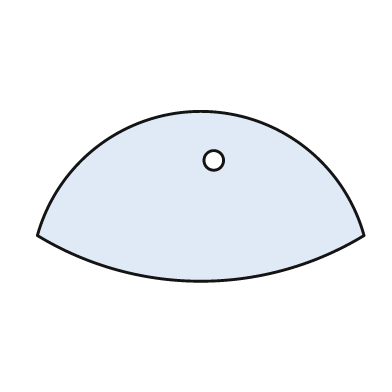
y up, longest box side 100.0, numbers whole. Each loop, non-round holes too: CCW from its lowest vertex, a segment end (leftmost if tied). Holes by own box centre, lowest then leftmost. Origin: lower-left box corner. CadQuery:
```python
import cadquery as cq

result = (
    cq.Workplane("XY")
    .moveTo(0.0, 14.0)
    .threePointArc((50.0, 0.0), (100.0, 14.0))
    .threePointArc((50.0, 52.0), (0.0, 14.0))
    .close()
    .moveTo(54.0, 37.0)
    .circle(3.0)
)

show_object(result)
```